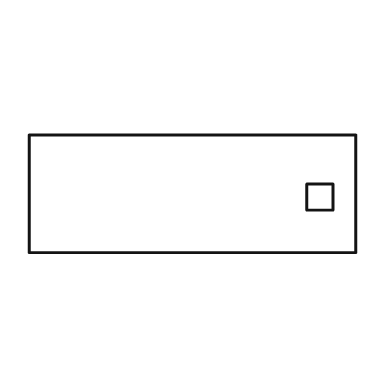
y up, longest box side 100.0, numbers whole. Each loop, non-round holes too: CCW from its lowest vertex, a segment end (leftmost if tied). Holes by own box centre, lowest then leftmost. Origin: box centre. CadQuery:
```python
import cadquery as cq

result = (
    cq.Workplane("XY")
    .moveTo(-50.0, -18.0)
    .lineTo(50.0, -18.0)
    .lineTo(50.0, 18.0)
    .lineTo(-50.0, 18.0)
    .close()
    .moveTo(35.0, -5.0)
    .lineTo(43.0, -5.0)
    .lineTo(43.0, 3.0)
    .lineTo(35.0, 3.0)
    .close()
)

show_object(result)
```